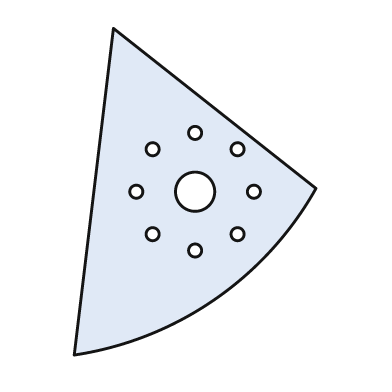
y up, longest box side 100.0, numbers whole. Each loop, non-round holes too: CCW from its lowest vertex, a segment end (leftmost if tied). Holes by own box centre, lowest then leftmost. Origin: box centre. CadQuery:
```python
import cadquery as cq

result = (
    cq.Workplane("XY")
    .moveTo(-37.0, -50.0)
    .threePointArc((6.0, -33.0), (37.0, 1.0))
    .lineTo(-25.0, 50.0)
    .close()
    .moveTo(0.0, -18.0)
    .circle(2.0)
    .moveTo(-13.0, -13.0)
    .circle(2.0)
    .moveTo(13.0, -13.0)
    .circle(2.0)
    .moveTo(-18.0, 0.0)
    .circle(2.0)
    .moveTo(0.0, 0.0)
    .circle(6.0)
    .moveTo(18.0, 0.0)
    .circle(2.0)
    .moveTo(-13.0, 13.0)
    .circle(2.0)
    .moveTo(13.0, 13.0)
    .circle(2.0)
    .moveTo(0.0, 18.0)
    .circle(2.0)
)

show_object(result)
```